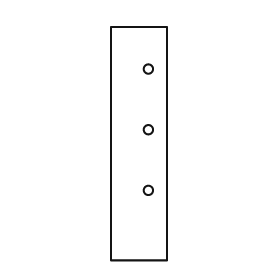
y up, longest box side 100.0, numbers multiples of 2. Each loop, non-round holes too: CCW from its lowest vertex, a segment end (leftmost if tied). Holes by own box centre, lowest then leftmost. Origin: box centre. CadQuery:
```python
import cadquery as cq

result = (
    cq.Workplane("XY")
    .moveTo(-12.0, -50.0)
    .lineTo(12.0, -50.0)
    .lineTo(12.0, 50.0)
    .lineTo(-12.0, 50.0)
    .close()
    .moveTo(4.0, -20.0)
    .circle(2.0)
    .moveTo(4.0, 6.0)
    .circle(2.0)
    .moveTo(4.0, 32.0)
    .circle(2.0)
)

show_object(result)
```